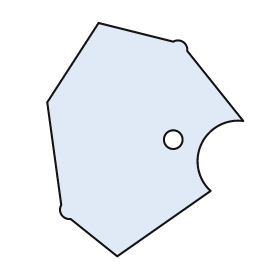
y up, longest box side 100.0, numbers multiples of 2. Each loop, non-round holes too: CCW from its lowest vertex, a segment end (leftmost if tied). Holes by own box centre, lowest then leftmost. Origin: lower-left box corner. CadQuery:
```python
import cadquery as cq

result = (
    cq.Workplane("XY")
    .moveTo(30.0, 0.0)
    .lineTo(70.0, 28.0)
    .threePointArc((66.0, 48.0), (84.0, 58.0))
    .lineTo(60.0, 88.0)
    .threePointArc((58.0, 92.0), (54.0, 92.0))
    .lineTo(22.0, 100.0)
    .lineTo(0.0, 66.0)
    .lineTo(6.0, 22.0)
    .threePointArc((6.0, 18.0), (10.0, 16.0))
    .close()
    .moveTo(54.0, 50.0)
    .circle(4.0)
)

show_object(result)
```